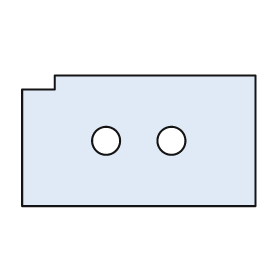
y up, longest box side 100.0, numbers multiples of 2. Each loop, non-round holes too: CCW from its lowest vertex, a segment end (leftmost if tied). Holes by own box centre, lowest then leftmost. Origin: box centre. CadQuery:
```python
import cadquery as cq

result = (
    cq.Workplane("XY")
    .moveTo(-50.0, -28.0)
    .lineTo(50.0, -28.0)
    .lineTo(50.0, 28.0)
    .lineTo(-36.0, 28.0)
    .lineTo(-36.0, 22.0)
    .lineTo(-50.0, 22.0)
    .close()
    .moveTo(-14.0, 0.0)
    .circle(6.0)
    .moveTo(14.0, 0.0)
    .circle(6.0)
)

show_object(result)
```